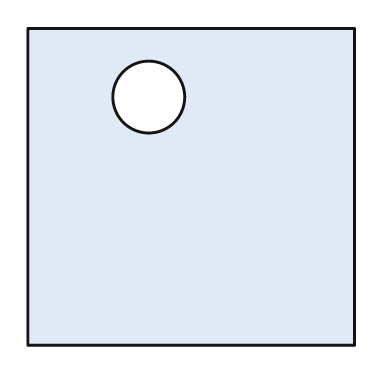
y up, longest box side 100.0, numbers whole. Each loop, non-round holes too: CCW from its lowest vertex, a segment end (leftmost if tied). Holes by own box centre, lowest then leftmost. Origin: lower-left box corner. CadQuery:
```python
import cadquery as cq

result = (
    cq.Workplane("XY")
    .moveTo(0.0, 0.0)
    .lineTo(100.0, 0.0)
    .lineTo(100.0, 97.0)
    .lineTo(0.0, 97.0)
    .close()
    .moveTo(37.0, 76.0)
    .circle(11.0)
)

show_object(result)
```